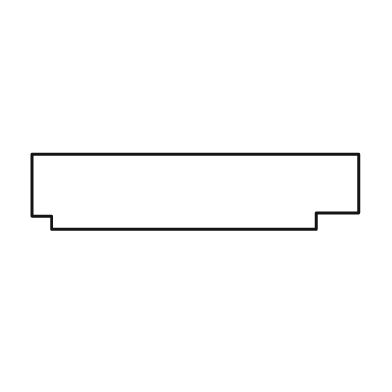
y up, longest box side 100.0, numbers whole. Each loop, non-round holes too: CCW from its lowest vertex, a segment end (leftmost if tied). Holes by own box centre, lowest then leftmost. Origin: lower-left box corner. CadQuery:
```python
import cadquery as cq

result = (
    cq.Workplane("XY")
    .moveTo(6.0, 0.0)
    .lineTo(87.0, 0.0)
    .lineTo(87.0, 5.0)
    .lineTo(100.0, 5.0)
    .lineTo(100.0, 23.0)
    .lineTo(0.0, 23.0)
    .lineTo(0.0, 4.0)
    .lineTo(6.0, 4.0)
    .close()
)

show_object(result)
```